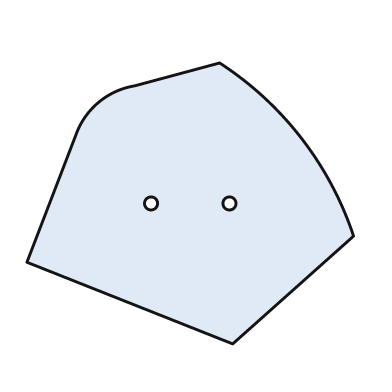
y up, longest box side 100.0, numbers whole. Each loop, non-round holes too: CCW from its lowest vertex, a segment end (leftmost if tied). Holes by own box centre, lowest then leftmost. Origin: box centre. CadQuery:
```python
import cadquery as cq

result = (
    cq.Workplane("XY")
    .moveTo(13.0, -43.0)
    .lineTo(50.0, -10.0)
    .threePointArc((34.0, 20.0), (9.0, 43.0))
    .lineTo(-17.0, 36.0)
    .threePointArc((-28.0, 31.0), (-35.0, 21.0))
    .lineTo(-50.0, -18.0)
    .close()
    .moveTo(-12.0, 0.0)
    .circle(2.0)
    .moveTo(12.0, 0.0)
    .circle(2.0)
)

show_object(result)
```